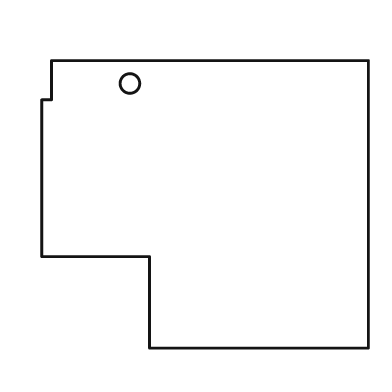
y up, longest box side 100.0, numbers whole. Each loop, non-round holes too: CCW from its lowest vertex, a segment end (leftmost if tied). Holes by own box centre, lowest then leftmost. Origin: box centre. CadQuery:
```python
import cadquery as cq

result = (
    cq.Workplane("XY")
    .moveTo(-17.0, -44.0)
    .lineTo(50.0, -44.0)
    .lineTo(50.0, 44.0)
    .lineTo(-47.0, 44.0)
    .lineTo(-47.0, 32.0)
    .lineTo(-50.0, 32.0)
    .lineTo(-50.0, -16.0)
    .lineTo(-17.0, -16.0)
    .close()
    .moveTo(-23.0, 37.0)
    .circle(3.0)
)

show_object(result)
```